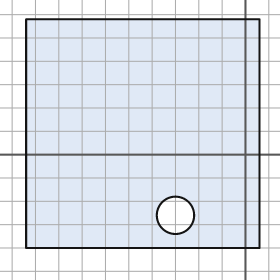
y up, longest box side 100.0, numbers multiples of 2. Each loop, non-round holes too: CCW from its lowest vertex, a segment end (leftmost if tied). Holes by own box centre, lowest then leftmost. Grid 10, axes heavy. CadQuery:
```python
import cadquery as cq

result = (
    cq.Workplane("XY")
    .moveTo(-94.0, -40.0)
    .lineTo(6.0, -40.0)
    .lineTo(6.0, 58.0)
    .lineTo(-94.0, 58.0)
    .close()
    .moveTo(-30.0, -26.0)
    .circle(8.0)
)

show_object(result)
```